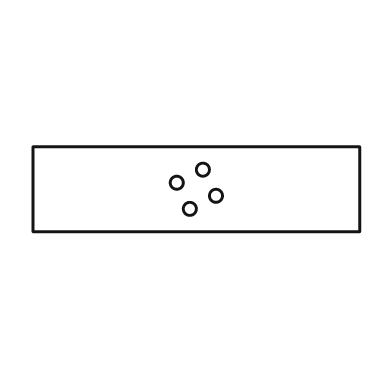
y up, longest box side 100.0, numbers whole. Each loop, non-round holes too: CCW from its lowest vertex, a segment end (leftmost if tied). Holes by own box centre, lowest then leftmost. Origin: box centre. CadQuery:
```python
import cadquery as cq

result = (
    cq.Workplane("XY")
    .moveTo(-50.0, -13.0)
    .lineTo(50.0, -13.0)
    .lineTo(50.0, 13.0)
    .lineTo(-50.0, 13.0)
    .close()
    .moveTo(-2.0, -6.0)
    .circle(2.0)
    .moveTo(6.0, -2.0)
    .circle(2.0)
    .moveTo(-6.0, 2.0)
    .circle(2.0)
    .moveTo(2.0, 6.0)
    .circle(2.0)
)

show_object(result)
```